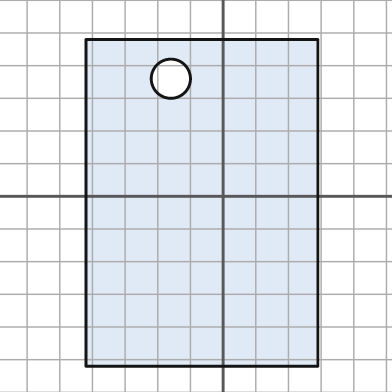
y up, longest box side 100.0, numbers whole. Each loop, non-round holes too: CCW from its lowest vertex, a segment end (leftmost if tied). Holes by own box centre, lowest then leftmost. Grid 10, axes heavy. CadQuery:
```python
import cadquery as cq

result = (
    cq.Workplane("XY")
    .moveTo(-42.0, -52.0)
    .lineTo(29.0, -52.0)
    .lineTo(29.0, 48.0)
    .lineTo(-42.0, 48.0)
    .close()
    .moveTo(-16.0, 36.0)
    .circle(6.0)
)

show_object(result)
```